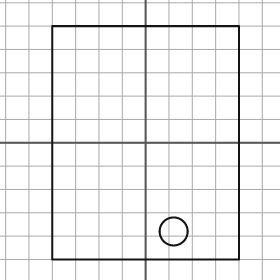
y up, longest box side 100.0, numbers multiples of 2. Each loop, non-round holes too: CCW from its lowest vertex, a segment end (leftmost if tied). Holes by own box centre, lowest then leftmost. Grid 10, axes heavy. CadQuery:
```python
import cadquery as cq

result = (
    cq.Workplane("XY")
    .moveTo(-40.0, -50.0)
    .lineTo(40.0, -50.0)
    .lineTo(40.0, 50.0)
    .lineTo(-40.0, 50.0)
    .close()
    .moveTo(12.0, -38.0)
    .circle(6.0)
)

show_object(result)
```